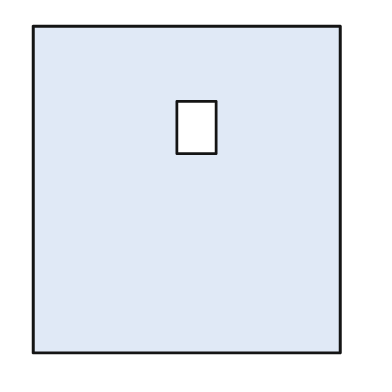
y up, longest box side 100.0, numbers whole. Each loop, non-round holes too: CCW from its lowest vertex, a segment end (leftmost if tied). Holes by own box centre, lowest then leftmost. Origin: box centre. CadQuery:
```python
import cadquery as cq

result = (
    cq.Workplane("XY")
    .moveTo(-47.0, -50.0)
    .lineTo(47.0, -50.0)
    .lineTo(47.0, 50.0)
    .lineTo(-47.0, 50.0)
    .close()
    .moveTo(-3.0, 11.0)
    .lineTo(9.0, 11.0)
    .lineTo(9.0, 27.0)
    .lineTo(-3.0, 27.0)
    .close()
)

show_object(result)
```